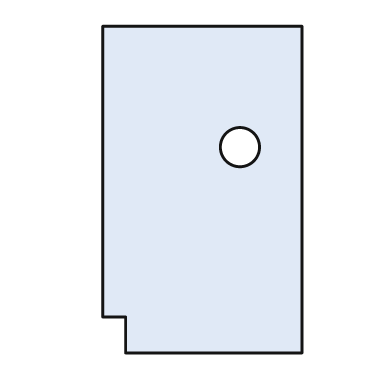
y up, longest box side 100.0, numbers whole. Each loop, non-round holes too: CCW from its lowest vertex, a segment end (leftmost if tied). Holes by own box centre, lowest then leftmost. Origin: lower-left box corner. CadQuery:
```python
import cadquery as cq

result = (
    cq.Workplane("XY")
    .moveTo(7.0, 0.0)
    .lineTo(61.0, 0.0)
    .lineTo(61.0, 100.0)
    .lineTo(0.0, 100.0)
    .lineTo(0.0, 11.0)
    .lineTo(7.0, 11.0)
    .close()
    .moveTo(42.0, 63.0)
    .circle(6.0)
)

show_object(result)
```